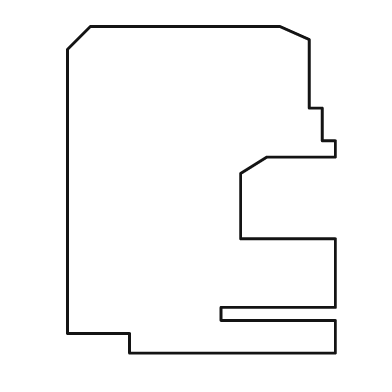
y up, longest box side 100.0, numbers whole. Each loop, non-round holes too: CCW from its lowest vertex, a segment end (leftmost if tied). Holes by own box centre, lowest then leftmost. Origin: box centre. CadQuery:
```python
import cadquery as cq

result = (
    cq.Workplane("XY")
    .moveTo(-22.0, -50.0)
    .lineTo(41.0, -50.0)
    .lineTo(41.0, -40.0)
    .lineTo(6.0, -40.0)
    .lineTo(6.0, -36.0)
    .lineTo(41.0, -36.0)
    .lineTo(41.0, -15.0)
    .lineTo(12.0, -15.0)
    .lineTo(12.0, 5.0)
    .lineTo(20.0, 10.0)
    .lineTo(41.0, 10.0)
    .lineTo(41.0, 15.0)
    .lineTo(37.0, 15.0)
    .lineTo(37.0, 25.0)
    .lineTo(33.0, 25.0)
    .lineTo(33.0, 46.0)
    .lineTo(24.0, 50.0)
    .lineTo(-34.0, 50.0)
    .lineTo(-41.0, 43.0)
    .lineTo(-41.0, -44.0)
    .lineTo(-22.0, -44.0)
    .close()
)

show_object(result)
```